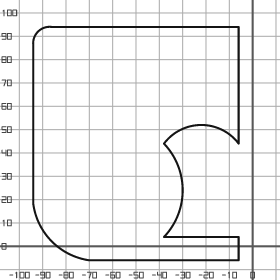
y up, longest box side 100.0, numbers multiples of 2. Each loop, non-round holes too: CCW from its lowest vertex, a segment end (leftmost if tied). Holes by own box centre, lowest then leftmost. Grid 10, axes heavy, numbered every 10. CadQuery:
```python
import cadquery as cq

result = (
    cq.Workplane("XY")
    .moveTo(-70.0, -6.0)
    .lineTo(-6.0, -6.0)
    .lineTo(-6.0, 4.0)
    .lineTo(-38.0, 4.0)
    .threePointArc((-30.0, 24.0), (-38.0, 44.0))
    .threePointArc((-22.0, 52.0), (-6.0, 44.0))
    .lineTo(-6.0, 94.0)
    .lineTo(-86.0, 94.0)
    .threePointArc((-92.0, 92.0), (-94.0, 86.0))
    .lineTo(-94.0, 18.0)
    .threePointArc((-86.0, 2.0), (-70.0, -6.0))
    .close()
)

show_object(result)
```